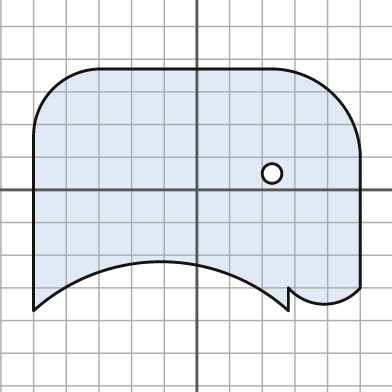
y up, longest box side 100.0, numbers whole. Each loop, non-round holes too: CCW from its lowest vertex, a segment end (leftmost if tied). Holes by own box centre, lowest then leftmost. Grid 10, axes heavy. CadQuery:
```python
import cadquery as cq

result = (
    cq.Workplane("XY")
    .moveTo(-50.0, -37.0)
    .threePointArc((-11.0, -22.0), (28.0, -37.0))
    .lineTo(28.0, -30.0)
    .threePointArc((39.0, -35.0), (50.0, -30.0))
    .lineTo(50.0, 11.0)
    .threePointArc((42.0, 29.0), (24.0, 37.0))
    .lineTo(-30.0, 37.0)
    .threePointArc((-44.0, 31.0), (-50.0, 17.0))
    .close()
    .moveTo(23.0, 5.0)
    .circle(3.0)
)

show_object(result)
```